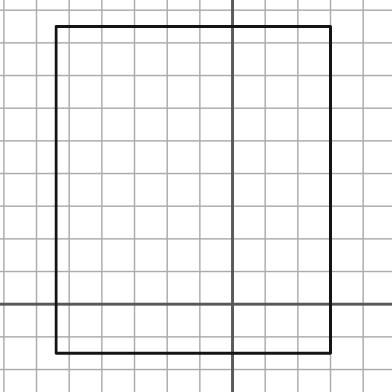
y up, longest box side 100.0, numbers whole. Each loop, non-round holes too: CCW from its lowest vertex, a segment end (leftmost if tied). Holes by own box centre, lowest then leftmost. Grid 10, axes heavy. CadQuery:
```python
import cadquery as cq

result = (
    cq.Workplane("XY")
    .moveTo(-54.0, -15.0)
    .lineTo(30.0, -15.0)
    .lineTo(30.0, 85.0)
    .lineTo(-54.0, 85.0)
    .close()
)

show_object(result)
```